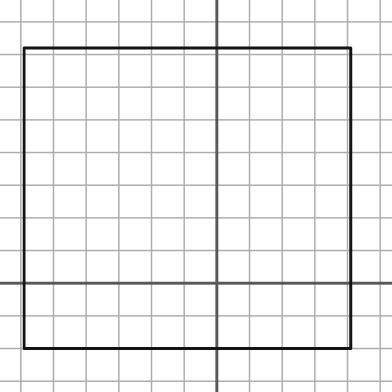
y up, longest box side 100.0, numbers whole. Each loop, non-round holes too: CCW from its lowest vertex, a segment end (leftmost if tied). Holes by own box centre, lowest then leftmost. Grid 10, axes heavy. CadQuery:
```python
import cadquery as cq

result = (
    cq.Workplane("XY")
    .moveTo(-59.0, -20.0)
    .lineTo(41.0, -20.0)
    .lineTo(41.0, 72.0)
    .lineTo(-59.0, 72.0)
    .close()
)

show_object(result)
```